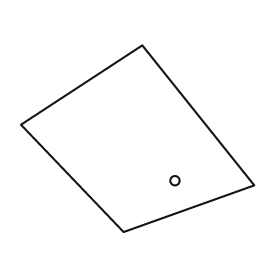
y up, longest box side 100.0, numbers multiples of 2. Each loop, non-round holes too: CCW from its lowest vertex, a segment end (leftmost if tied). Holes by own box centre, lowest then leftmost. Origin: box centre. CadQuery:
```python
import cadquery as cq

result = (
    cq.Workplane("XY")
    .moveTo(-6.0, -40.0)
    .lineTo(50.0, -20.0)
    .lineTo(2.0, 40.0)
    .lineTo(-50.0, 6.0)
    .close()
    .moveTo(16.0, -18.0)
    .circle(2.0)
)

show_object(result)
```